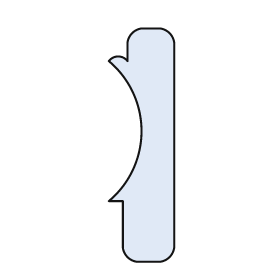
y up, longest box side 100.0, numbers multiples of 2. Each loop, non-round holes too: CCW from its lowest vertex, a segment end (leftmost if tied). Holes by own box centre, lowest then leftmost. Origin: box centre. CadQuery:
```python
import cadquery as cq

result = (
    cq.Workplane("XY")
    .moveTo(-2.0, -50.0)
    .lineTo(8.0, -50.0)
    .threePointArc((12.0, -48.0), (14.0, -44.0))
    .lineTo(14.0, 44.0)
    .threePointArc((12.0, 48.0), (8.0, 50.0))
    .lineTo(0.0, 50.0)
    .threePointArc((-4.0, 48.0), (-6.0, 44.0))
    .lineTo(-6.0, 36.0)
    .threePointArc((-10.0, 38.0), (-14.0, 36.0))
    .threePointArc((0.0, 6.0), (-14.0, -24.0))
    .lineTo(-8.0, -24.0)
    .lineTo(-8.0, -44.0)
    .threePointArc((-6.0, -48.0), (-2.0, -50.0))
    .close()
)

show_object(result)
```